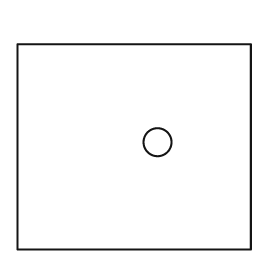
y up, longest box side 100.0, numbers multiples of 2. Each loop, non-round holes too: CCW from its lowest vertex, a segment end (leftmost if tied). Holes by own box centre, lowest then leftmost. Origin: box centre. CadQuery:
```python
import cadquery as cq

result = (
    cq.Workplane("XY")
    .moveTo(-50.0, -44.0)
    .lineTo(50.0, -44.0)
    .lineTo(50.0, 44.0)
    .lineTo(-50.0, 44.0)
    .close()
    .moveTo(10.0, 2.0)
    .circle(6.0)
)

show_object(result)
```